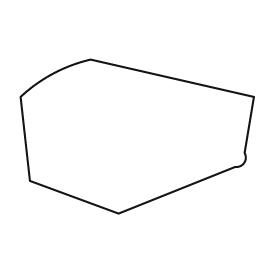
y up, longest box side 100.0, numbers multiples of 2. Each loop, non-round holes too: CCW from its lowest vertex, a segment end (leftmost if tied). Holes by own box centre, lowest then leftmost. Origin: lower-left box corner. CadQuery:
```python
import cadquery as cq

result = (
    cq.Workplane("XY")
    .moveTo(42.0, 0.0)
    .lineTo(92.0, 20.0)
    .threePointArc((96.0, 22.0), (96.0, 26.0))
    .lineTo(100.0, 50.0)
    .lineTo(30.0, 66.0)
    .threePointArc((14.0, 60.0), (0.0, 50.0))
    .lineTo(4.0, 14.0)
    .close()
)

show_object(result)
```